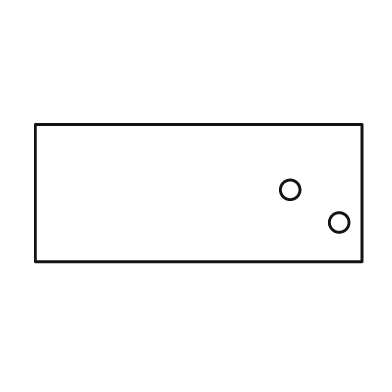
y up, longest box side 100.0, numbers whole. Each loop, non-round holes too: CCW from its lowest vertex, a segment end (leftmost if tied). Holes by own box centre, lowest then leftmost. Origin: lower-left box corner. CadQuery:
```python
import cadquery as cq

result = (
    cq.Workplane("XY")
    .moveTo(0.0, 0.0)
    .lineTo(100.0, 0.0)
    .lineTo(100.0, 42.0)
    .lineTo(0.0, 42.0)
    .close()
    .moveTo(93.0, 12.0)
    .circle(3.0)
    .moveTo(78.0, 22.0)
    .circle(3.0)
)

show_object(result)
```